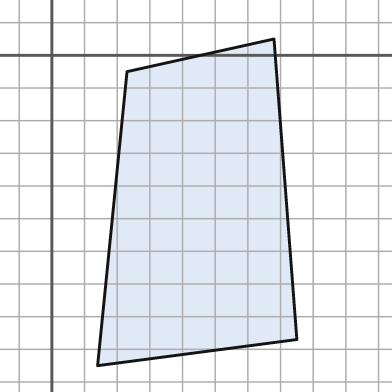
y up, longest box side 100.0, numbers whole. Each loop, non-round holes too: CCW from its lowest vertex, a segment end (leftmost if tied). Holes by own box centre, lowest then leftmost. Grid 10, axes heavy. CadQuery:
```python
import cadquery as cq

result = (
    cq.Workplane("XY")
    .moveTo(14.0, -95.0)
    .lineTo(75.0, -87.0)
    .lineTo(68.0, 5.0)
    .lineTo(23.0, -5.0)
    .close()
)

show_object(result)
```